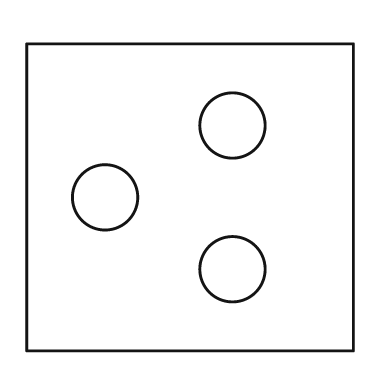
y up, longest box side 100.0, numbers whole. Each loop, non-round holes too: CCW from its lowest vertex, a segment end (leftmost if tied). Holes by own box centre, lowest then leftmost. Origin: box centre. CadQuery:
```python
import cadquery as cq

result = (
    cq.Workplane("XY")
    .moveTo(-50.0, -47.0)
    .lineTo(50.0, -47.0)
    .lineTo(50.0, 47.0)
    .lineTo(-50.0, 47.0)
    .close()
    .moveTo(13.0, -22.0)
    .circle(10.0)
    .moveTo(-26.0, 0.0)
    .circle(10.0)
    .moveTo(13.0, 22.0)
    .circle(10.0)
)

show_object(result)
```